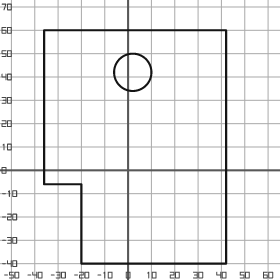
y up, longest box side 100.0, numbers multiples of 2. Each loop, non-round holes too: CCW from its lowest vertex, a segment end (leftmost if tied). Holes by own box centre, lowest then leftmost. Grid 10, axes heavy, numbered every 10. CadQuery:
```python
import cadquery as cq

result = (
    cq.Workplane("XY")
    .moveTo(-20.0, -40.0)
    .lineTo(42.0, -40.0)
    .lineTo(42.0, 60.0)
    .lineTo(-36.0, 60.0)
    .lineTo(-36.0, -6.0)
    .lineTo(-20.0, -6.0)
    .close()
    .moveTo(2.0, 42.0)
    .circle(8.0)
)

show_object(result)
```